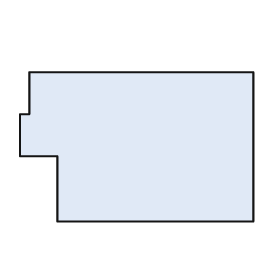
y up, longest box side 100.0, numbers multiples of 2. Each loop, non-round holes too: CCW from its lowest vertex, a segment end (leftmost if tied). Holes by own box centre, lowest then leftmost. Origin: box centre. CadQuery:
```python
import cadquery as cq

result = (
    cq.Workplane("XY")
    .moveTo(-34.0, -32.0)
    .lineTo(50.0, -32.0)
    .lineTo(50.0, 32.0)
    .lineTo(-46.0, 32.0)
    .lineTo(-46.0, 14.0)
    .lineTo(-50.0, 14.0)
    .lineTo(-50.0, -4.0)
    .lineTo(-34.0, -4.0)
    .close()
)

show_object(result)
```